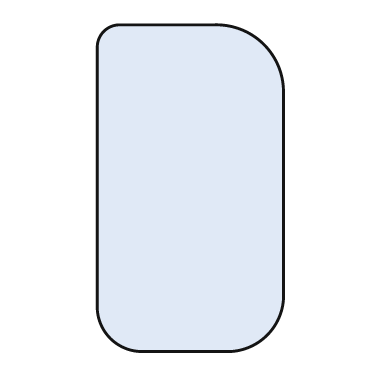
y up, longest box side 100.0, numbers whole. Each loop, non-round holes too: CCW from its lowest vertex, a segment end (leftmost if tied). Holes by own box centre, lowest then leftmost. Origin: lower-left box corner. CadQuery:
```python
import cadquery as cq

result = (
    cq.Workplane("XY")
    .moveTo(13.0, 0.0)
    .lineTo(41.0, 0.0)
    .threePointArc((52.0, 5.0), (57.0, 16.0))
    .lineTo(57.0, 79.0)
    .threePointArc((51.0, 94.0), (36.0, 100.0))
    .lineTo(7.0, 100.0)
    .threePointArc((2.0, 98.0), (0.0, 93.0))
    .lineTo(0.0, 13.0)
    .threePointArc((4.0, 4.0), (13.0, 0.0))
    .close()
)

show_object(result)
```